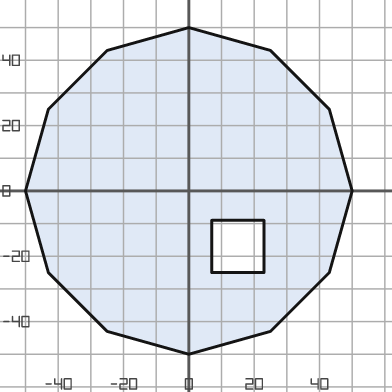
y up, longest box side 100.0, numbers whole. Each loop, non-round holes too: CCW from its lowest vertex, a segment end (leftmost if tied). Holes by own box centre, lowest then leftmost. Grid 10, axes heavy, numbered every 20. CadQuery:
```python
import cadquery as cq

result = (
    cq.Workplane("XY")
    .moveTo(0.0, -50.0)
    .lineTo(25.0, -43.0)
    .lineTo(43.0, -25.0)
    .lineTo(50.0, 0.0)
    .lineTo(43.0, 25.0)
    .lineTo(25.0, 43.0)
    .lineTo(0.0, 50.0)
    .lineTo(-25.0, 43.0)
    .lineTo(-43.0, 25.0)
    .lineTo(-50.0, 0.0)
    .lineTo(-43.0, -25.0)
    .lineTo(-25.0, -43.0)
    .close()
    .moveTo(7.0, -25.0)
    .lineTo(23.0, -25.0)
    .lineTo(23.0, -9.0)
    .lineTo(7.0, -9.0)
    .close()
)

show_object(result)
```